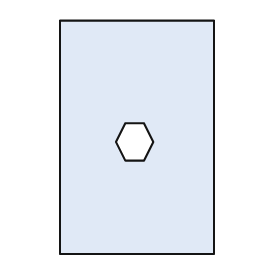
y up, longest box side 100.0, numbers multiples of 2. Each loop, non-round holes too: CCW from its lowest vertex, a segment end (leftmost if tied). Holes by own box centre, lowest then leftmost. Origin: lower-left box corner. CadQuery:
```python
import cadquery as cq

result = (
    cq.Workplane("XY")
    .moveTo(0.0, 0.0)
    .lineTo(66.0, 0.0)
    .lineTo(66.0, 100.0)
    .lineTo(0.0, 100.0)
    .close()
    .moveTo(28.0, 40.0)
    .lineTo(36.0, 40.0)
    .lineTo(40.0, 48.0)
    .lineTo(36.0, 56.0)
    .lineTo(28.0, 56.0)
    .lineTo(24.0, 48.0)
    .close()
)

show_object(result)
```